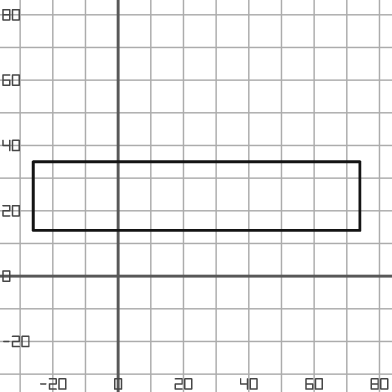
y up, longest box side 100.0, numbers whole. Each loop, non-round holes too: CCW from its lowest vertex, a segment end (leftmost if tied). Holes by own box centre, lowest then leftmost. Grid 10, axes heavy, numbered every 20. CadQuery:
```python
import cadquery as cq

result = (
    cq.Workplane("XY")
    .moveTo(-26.0, 14.0)
    .lineTo(74.0, 14.0)
    .lineTo(74.0, 35.0)
    .lineTo(-26.0, 35.0)
    .close()
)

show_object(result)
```